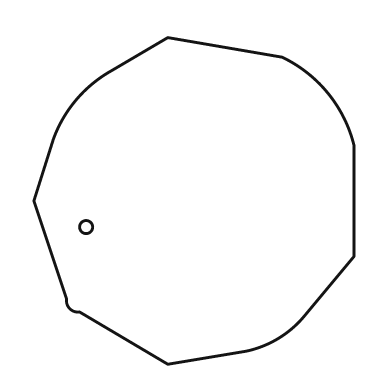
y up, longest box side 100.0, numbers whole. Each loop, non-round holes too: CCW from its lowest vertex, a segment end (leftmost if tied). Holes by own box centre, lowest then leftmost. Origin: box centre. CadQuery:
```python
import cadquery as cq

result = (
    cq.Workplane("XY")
    .moveTo(-8.0, -50.0)
    .lineTo(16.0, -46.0)
    .threePointArc((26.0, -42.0), (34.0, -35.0))
    .lineTo(49.0, -17.0)
    .lineTo(49.0, 17.0)
    .threePointArc((41.0, 33.0), (27.0, 44.0))
    .lineTo(-8.0, 50.0)
    .lineTo(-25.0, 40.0)
    .threePointArc((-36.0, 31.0), (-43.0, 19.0))
    .lineTo(-49.0, 0.0)
    .lineTo(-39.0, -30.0)
    .threePointArc((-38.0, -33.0), (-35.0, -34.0))
    .close()
    .moveTo(-33.0, -8.0)
    .circle(2.0)
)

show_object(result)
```